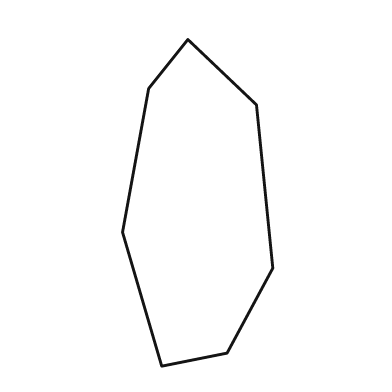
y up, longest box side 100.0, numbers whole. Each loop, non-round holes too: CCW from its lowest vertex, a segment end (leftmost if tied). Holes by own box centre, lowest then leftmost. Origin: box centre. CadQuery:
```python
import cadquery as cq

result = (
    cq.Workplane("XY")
    .moveTo(-11.0, -50.0)
    .lineTo(9.0, -46.0)
    .lineTo(23.0, -20.0)
    .lineTo(18.0, 30.0)
    .lineTo(-3.0, 50.0)
    .lineTo(-15.0, 35.0)
    .lineTo(-23.0, -9.0)
    .close()
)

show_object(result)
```